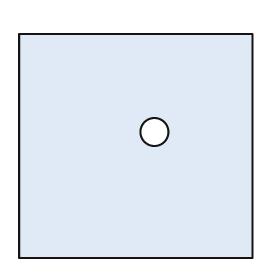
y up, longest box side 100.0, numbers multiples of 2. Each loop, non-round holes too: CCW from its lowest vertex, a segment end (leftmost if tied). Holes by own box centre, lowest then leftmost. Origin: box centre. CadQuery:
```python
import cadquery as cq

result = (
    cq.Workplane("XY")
    .moveTo(-50.0, -48.0)
    .lineTo(50.0, -48.0)
    .lineTo(50.0, 48.0)
    .lineTo(-50.0, 48.0)
    .close()
    .moveTo(8.0, 6.0)
    .circle(6.0)
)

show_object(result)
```